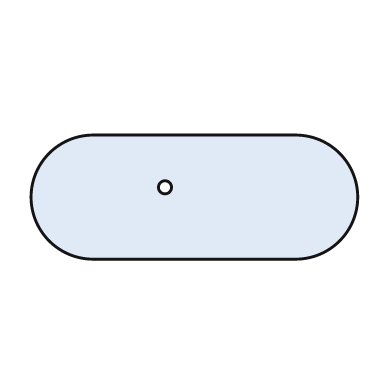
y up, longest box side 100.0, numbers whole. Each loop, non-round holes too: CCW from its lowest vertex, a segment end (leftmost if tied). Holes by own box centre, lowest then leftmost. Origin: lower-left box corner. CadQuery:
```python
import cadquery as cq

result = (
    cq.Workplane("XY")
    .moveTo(19.0, 0.0)
    .lineTo(81.0, 0.0)
    .threePointArc((100.0, 19.0), (81.0, 38.0))
    .lineTo(19.0, 38.0)
    .threePointArc((0.0, 19.0), (19.0, 0.0))
    .close()
    .moveTo(41.0, 22.0)
    .circle(2.0)
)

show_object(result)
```